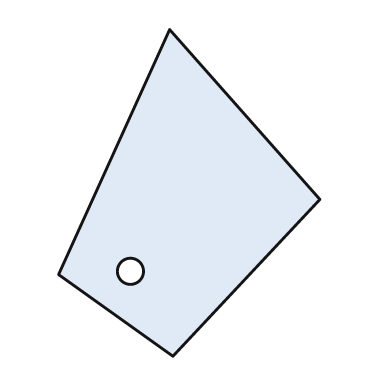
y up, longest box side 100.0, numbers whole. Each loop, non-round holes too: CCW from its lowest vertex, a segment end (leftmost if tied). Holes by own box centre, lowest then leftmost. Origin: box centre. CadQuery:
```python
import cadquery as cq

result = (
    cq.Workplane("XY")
    .moveTo(-5.0, -50.0)
    .lineTo(40.0, -2.0)
    .lineTo(-6.0, 50.0)
    .lineTo(-40.0, -25.0)
    .close()
    .moveTo(-18.0, -24.0)
    .circle(4.0)
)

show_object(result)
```